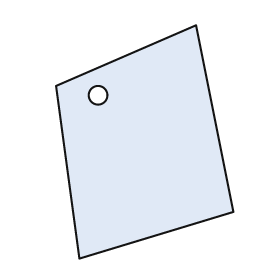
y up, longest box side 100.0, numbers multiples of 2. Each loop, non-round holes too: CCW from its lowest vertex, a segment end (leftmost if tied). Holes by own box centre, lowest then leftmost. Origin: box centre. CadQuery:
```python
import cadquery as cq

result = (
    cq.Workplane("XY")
    .moveTo(-28.0, -50.0)
    .lineTo(38.0, -30.0)
    .lineTo(22.0, 50.0)
    .lineTo(-38.0, 24.0)
    .close()
    .moveTo(-20.0, 20.0)
    .circle(4.0)
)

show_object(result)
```